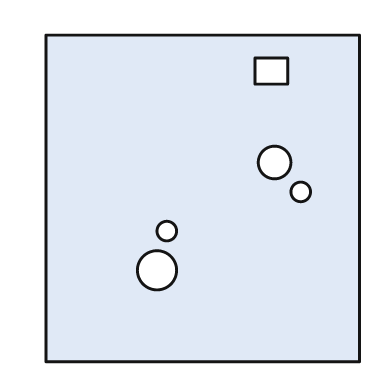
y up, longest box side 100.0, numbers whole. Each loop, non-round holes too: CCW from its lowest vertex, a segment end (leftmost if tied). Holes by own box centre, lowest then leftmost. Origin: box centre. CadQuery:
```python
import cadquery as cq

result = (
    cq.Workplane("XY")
    .moveTo(-48.0, -50.0)
    .lineTo(48.0, -50.0)
    .lineTo(48.0, 50.0)
    .lineTo(-48.0, 50.0)
    .close()
    .moveTo(-14.0, -22.0)
    .circle(6.0)
    .moveTo(-11.0, -10.0)
    .circle(3.0)
    .moveTo(30.0, 2.0)
    .circle(3.0)
    .moveTo(22.0, 11.0)
    .circle(5.0)
    .moveTo(16.0, 35.0)
    .lineTo(26.0, 35.0)
    .lineTo(26.0, 43.0)
    .lineTo(16.0, 43.0)
    .close()
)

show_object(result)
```